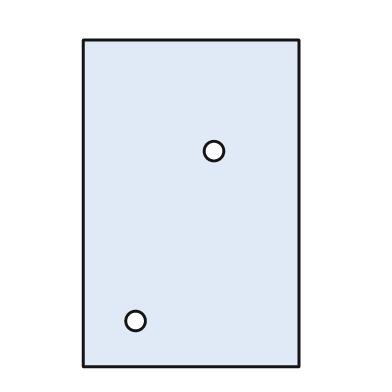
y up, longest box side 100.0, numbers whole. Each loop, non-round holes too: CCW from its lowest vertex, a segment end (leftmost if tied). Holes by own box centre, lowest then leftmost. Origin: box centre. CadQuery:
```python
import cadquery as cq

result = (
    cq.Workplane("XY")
    .moveTo(-33.0, -50.0)
    .lineTo(33.0, -50.0)
    .lineTo(33.0, 50.0)
    .lineTo(-33.0, 50.0)
    .close()
    .moveTo(-17.0, -36.0)
    .circle(3.0)
    .moveTo(7.0, 16.0)
    .circle(3.0)
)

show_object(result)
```